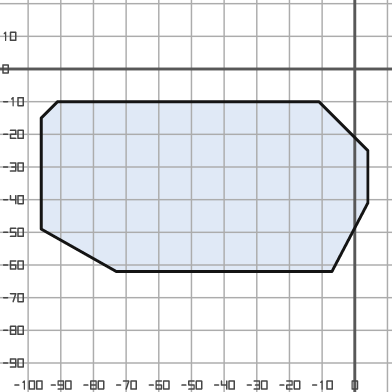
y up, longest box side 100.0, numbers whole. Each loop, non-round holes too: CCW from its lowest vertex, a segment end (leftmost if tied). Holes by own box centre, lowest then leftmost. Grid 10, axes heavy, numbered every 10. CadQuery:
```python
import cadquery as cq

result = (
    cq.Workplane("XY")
    .moveTo(-73.0, -62.0)
    .lineTo(-7.0, -62.0)
    .lineTo(4.0, -41.0)
    .lineTo(4.0, -25.0)
    .lineTo(-11.0, -10.0)
    .lineTo(-91.0, -10.0)
    .lineTo(-96.0, -15.0)
    .lineTo(-96.0, -49.0)
    .close()
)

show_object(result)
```